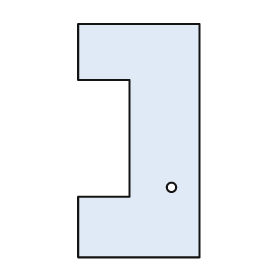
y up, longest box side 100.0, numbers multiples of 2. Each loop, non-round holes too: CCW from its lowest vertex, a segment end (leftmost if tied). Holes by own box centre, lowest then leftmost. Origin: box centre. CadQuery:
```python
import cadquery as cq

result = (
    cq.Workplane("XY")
    .moveTo(-26.0, -50.0)
    .lineTo(26.0, -50.0)
    .lineTo(26.0, 50.0)
    .lineTo(-26.0, 50.0)
    .lineTo(-26.0, 26.0)
    .lineTo(-4.0, 26.0)
    .lineTo(-4.0, -24.0)
    .lineTo(-26.0, -24.0)
    .close()
    .moveTo(14.0, -20.0)
    .circle(2.0)
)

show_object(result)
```